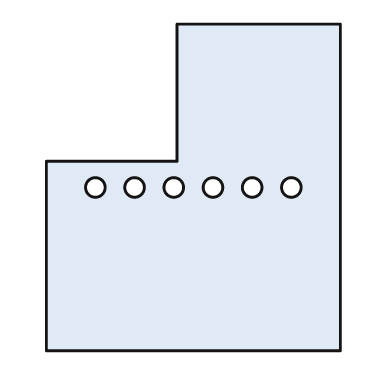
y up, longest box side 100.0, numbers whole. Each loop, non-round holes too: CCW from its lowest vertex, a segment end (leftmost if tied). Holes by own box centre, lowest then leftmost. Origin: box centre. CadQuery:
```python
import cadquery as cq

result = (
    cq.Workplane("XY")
    .moveTo(-45.0, -50.0)
    .lineTo(45.0, -50.0)
    .lineTo(45.0, 50.0)
    .lineTo(-5.0, 50.0)
    .lineTo(-5.0, 8.0)
    .lineTo(-45.0, 8.0)
    .close()
    .moveTo(-30.0, 0.0)
    .circle(3.0)
    .moveTo(-18.0, 0.0)
    .circle(3.0)
    .moveTo(-6.0, 0.0)
    .circle(3.0)
    .moveTo(6.0, 0.0)
    .circle(3.0)
    .moveTo(18.0, 0.0)
    .circle(3.0)
    .moveTo(30.0, 0.0)
    .circle(3.0)
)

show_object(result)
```